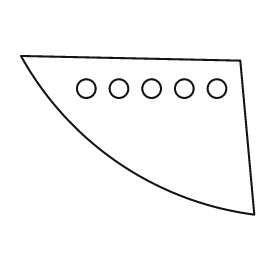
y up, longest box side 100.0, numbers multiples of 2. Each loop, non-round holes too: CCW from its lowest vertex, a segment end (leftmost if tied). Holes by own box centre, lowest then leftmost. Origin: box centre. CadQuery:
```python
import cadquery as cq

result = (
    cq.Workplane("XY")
    .moveTo(50.0, -34.0)
    .lineTo(44.0, 32.0)
    .lineTo(-50.0, 34.0)
    .threePointArc((-8.0, -12.0), (50.0, -34.0))
    .close()
    .moveTo(-22.0, 20.0)
    .circle(4.0)
    .moveTo(-8.0, 20.0)
    .circle(4.0)
    .moveTo(6.0, 20.0)
    .circle(4.0)
    .moveTo(20.0, 20.0)
    .circle(4.0)
    .moveTo(34.0, 20.0)
    .circle(4.0)
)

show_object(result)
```